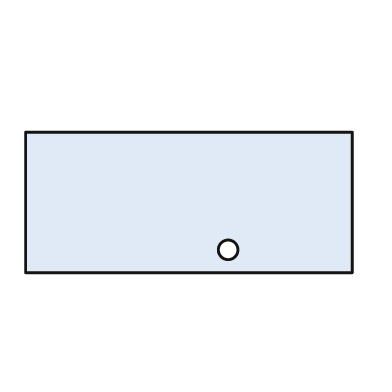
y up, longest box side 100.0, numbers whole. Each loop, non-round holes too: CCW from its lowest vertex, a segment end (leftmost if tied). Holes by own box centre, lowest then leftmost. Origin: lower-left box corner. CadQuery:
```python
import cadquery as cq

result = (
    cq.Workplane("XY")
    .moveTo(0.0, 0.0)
    .lineTo(100.0, 0.0)
    .lineTo(100.0, 43.0)
    .lineTo(0.0, 43.0)
    .close()
    .moveTo(62.0, 7.0)
    .circle(3.0)
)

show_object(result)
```